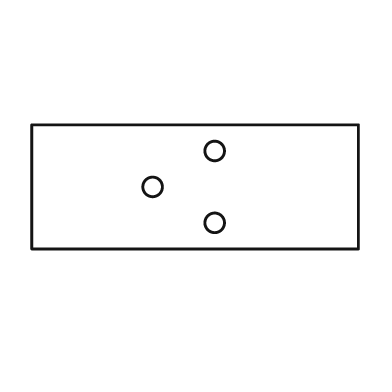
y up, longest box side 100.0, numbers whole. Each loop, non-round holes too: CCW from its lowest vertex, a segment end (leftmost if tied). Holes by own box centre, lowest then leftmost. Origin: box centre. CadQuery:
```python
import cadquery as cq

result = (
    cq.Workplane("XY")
    .moveTo(-50.0, -19.0)
    .lineTo(50.0, -19.0)
    .lineTo(50.0, 19.0)
    .lineTo(-50.0, 19.0)
    .close()
    .moveTo(6.0, -11.0)
    .circle(3.0)
    .moveTo(-13.0, 0.0)
    .circle(3.0)
    .moveTo(6.0, 11.0)
    .circle(3.0)
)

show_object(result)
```